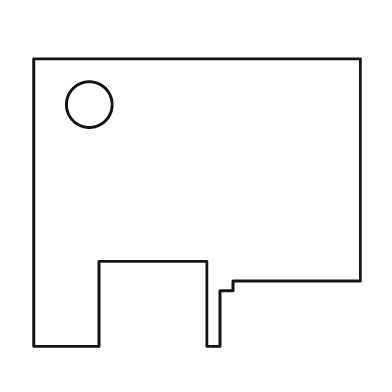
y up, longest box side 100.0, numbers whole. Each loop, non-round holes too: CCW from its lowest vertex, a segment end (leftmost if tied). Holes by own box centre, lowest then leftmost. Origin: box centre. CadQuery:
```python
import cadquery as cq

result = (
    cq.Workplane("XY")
    .moveTo(-50.0, -44.0)
    .lineTo(-30.0, -44.0)
    .lineTo(-30.0, -18.0)
    .lineTo(3.0, -18.0)
    .lineTo(3.0, -44.0)
    .lineTo(7.0, -44.0)
    .lineTo(7.0, -27.0)
    .lineTo(11.0, -27.0)
    .lineTo(11.0, -24.0)
    .lineTo(50.0, -24.0)
    .lineTo(50.0, 44.0)
    .lineTo(-50.0, 44.0)
    .close()
    .moveTo(-33.0, 30.0)
    .circle(7.0)
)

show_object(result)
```